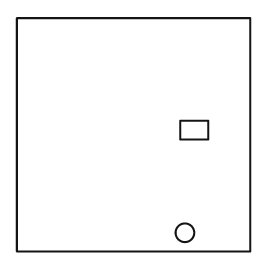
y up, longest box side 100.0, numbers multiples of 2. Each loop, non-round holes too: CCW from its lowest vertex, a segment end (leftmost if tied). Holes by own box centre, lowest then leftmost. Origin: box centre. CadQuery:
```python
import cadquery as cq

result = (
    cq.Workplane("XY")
    .moveTo(-50.0, -50.0)
    .lineTo(50.0, -50.0)
    .lineTo(50.0, 50.0)
    .lineTo(-50.0, 50.0)
    .close()
    .moveTo(22.0, -42.0)
    .circle(4.0)
    .moveTo(20.0, -2.0)
    .lineTo(32.0, -2.0)
    .lineTo(32.0, 6.0)
    .lineTo(20.0, 6.0)
    .close()
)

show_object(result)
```